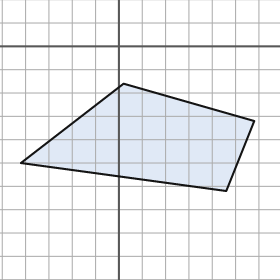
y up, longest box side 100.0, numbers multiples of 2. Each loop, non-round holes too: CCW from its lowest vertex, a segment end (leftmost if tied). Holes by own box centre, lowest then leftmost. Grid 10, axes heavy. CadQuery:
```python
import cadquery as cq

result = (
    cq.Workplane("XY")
    .moveTo(46.0, -62.0)
    .lineTo(58.0, -32.0)
    .lineTo(2.0, -16.0)
    .lineTo(-42.0, -50.0)
    .close()
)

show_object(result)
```